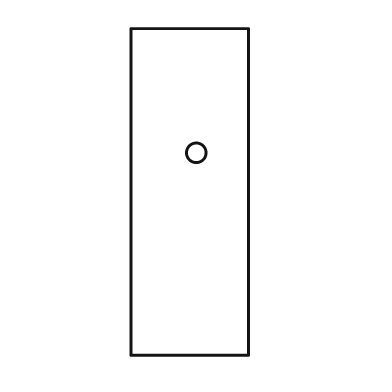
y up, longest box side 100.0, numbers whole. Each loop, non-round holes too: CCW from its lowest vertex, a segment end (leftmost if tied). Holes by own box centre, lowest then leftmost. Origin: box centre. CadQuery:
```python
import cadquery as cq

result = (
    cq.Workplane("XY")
    .moveTo(-18.0, -50.0)
    .lineTo(18.0, -50.0)
    .lineTo(18.0, 50.0)
    .lineTo(-18.0, 50.0)
    .close()
    .moveTo(2.0, 12.0)
    .circle(3.0)
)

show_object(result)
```